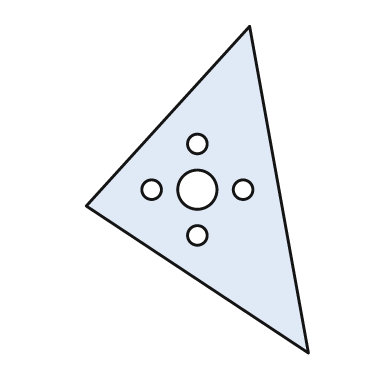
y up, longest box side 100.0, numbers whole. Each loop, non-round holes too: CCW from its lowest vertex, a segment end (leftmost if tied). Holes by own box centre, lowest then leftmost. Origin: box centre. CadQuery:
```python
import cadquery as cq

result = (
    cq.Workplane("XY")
    .moveTo(34.0, -50.0)
    .lineTo(16.0, 50.0)
    .lineTo(-34.0, -5.0)
    .close()
    .moveTo(0.0, -14.0)
    .circle(3.0)
    .moveTo(-14.0, 0.0)
    .circle(3.0)
    .moveTo(0.0, 0.0)
    .circle(6.0)
    .moveTo(14.0, 0.0)
    .circle(3.0)
    .moveTo(0.0, 14.0)
    .circle(3.0)
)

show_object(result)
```